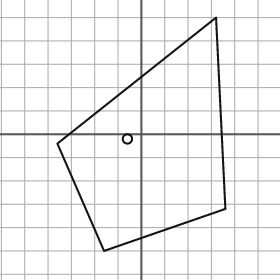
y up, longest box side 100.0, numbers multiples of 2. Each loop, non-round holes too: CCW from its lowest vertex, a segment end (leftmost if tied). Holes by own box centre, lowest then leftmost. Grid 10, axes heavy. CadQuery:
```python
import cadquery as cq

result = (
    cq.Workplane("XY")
    .moveTo(-16.0, -50.0)
    .lineTo(36.0, -32.0)
    .lineTo(32.0, 50.0)
    .lineTo(-36.0, -4.0)
    .close()
    .moveTo(-6.0, -2.0)
    .circle(2.0)
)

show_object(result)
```